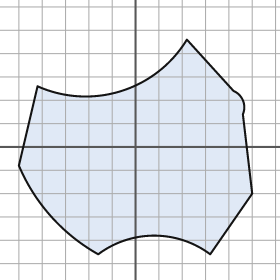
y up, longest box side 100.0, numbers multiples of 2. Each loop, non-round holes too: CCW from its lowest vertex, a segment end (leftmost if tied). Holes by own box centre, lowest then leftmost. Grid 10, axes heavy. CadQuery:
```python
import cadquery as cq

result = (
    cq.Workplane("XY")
    .moveTo(-16.0, -46.0)
    .threePointArc((8.0, -38.0), (32.0, -46.0))
    .lineTo(50.0, -20.0)
    .lineTo(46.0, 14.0)
    .threePointArc((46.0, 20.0), (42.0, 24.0))
    .lineTo(22.0, 46.0)
    .threePointArc((-6.0, 24.0), (-42.0, 26.0))
    .lineTo(-50.0, -8.0)
    .threePointArc((-36.0, -30.0), (-16.0, -46.0))
    .close()
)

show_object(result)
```